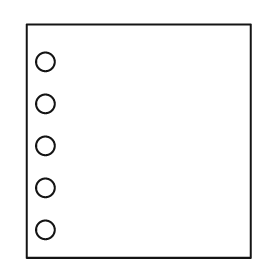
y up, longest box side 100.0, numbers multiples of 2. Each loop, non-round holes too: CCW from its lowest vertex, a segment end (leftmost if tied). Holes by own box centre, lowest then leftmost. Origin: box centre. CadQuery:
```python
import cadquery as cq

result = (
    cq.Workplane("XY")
    .moveTo(-48.0, -50.0)
    .lineTo(48.0, -50.0)
    .lineTo(48.0, 50.0)
    .lineTo(-48.0, 50.0)
    .close()
    .moveTo(-40.0, -38.0)
    .circle(4.0)
    .moveTo(-40.0, -20.0)
    .circle(4.0)
    .moveTo(-40.0, -2.0)
    .circle(4.0)
    .moveTo(-40.0, 16.0)
    .circle(4.0)
    .moveTo(-40.0, 34.0)
    .circle(4.0)
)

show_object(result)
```